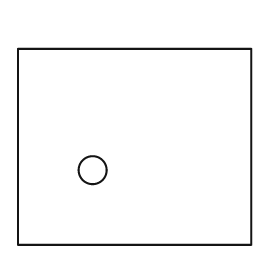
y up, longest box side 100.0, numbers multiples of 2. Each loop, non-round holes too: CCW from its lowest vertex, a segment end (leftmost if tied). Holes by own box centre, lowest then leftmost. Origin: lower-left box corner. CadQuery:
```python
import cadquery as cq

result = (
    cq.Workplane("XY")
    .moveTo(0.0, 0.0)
    .lineTo(100.0, 0.0)
    .lineTo(100.0, 84.0)
    .lineTo(0.0, 84.0)
    .close()
    .moveTo(32.0, 32.0)
    .circle(6.0)
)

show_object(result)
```